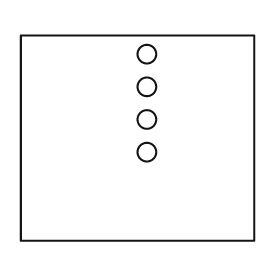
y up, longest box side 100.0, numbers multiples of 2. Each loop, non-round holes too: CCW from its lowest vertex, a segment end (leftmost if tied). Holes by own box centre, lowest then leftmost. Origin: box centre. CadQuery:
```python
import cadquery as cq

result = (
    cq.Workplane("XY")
    .moveTo(-50.0, -44.0)
    .lineTo(50.0, -44.0)
    .lineTo(50.0, 44.0)
    .lineTo(-50.0, 44.0)
    .close()
    .moveTo(4.0, -6.0)
    .circle(4.0)
    .moveTo(4.0, 8.0)
    .circle(4.0)
    .moveTo(4.0, 22.0)
    .circle(4.0)
    .moveTo(4.0, 36.0)
    .circle(4.0)
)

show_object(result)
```